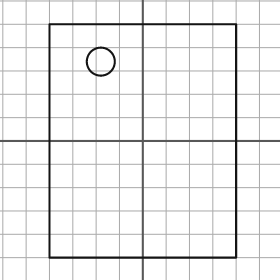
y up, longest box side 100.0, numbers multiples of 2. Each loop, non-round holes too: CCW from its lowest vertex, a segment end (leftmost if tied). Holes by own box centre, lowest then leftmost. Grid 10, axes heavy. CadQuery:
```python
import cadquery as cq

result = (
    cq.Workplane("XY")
    .moveTo(-40.0, -50.0)
    .lineTo(40.0, -50.0)
    .lineTo(40.0, 50.0)
    .lineTo(-40.0, 50.0)
    .close()
    .moveTo(-18.0, 34.0)
    .circle(6.0)
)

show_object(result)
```